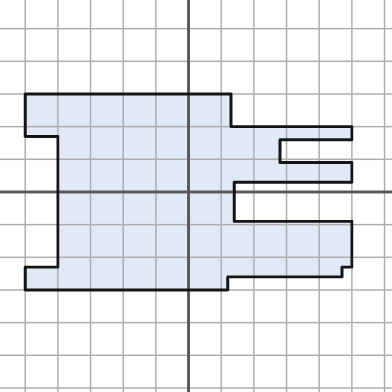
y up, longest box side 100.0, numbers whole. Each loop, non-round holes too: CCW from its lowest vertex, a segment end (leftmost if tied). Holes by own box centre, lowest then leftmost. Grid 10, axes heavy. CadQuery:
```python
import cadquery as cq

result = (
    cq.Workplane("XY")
    .moveTo(-50.0, -30.0)
    .lineTo(12.0, -30.0)
    .lineTo(12.0, -26.0)
    .lineTo(47.0, -26.0)
    .lineTo(47.0, -23.0)
    .lineTo(50.0, -23.0)
    .lineTo(50.0, -9.0)
    .lineTo(14.0, -9.0)
    .lineTo(14.0, 3.0)
    .lineTo(50.0, 3.0)
    .lineTo(50.0, 9.0)
    .lineTo(28.0, 9.0)
    .lineTo(28.0, 16.0)
    .lineTo(50.0, 16.0)
    .lineTo(50.0, 20.0)
    .lineTo(13.0, 20.0)
    .lineTo(13.0, 30.0)
    .lineTo(-50.0, 30.0)
    .lineTo(-50.0, 17.0)
    .lineTo(-40.0, 17.0)
    .lineTo(-40.0, -23.0)
    .lineTo(-50.0, -23.0)
    .close()
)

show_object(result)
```